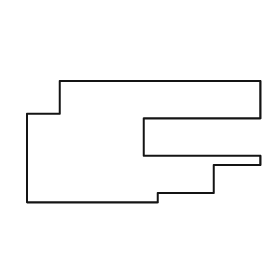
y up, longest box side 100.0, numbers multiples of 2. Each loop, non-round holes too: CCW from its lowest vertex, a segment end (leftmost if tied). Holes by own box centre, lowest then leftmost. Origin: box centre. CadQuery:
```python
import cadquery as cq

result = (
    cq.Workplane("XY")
    .moveTo(-50.0, -26.0)
    .lineTo(6.0, -26.0)
    .lineTo(6.0, -22.0)
    .lineTo(30.0, -22.0)
    .lineTo(30.0, -10.0)
    .lineTo(50.0, -10.0)
    .lineTo(50.0, -6.0)
    .lineTo(0.0, -6.0)
    .lineTo(0.0, 10.0)
    .lineTo(50.0, 10.0)
    .lineTo(50.0, 26.0)
    .lineTo(-36.0, 26.0)
    .lineTo(-36.0, 12.0)
    .lineTo(-50.0, 12.0)
    .close()
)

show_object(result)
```